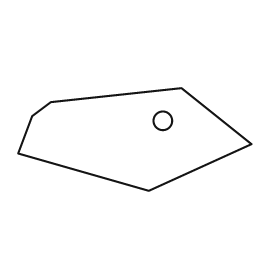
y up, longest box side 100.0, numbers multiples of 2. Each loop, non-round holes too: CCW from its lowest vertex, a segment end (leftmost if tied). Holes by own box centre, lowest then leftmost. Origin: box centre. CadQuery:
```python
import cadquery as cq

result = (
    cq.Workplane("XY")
    .moveTo(6.0, -22.0)
    .lineTo(50.0, -2.0)
    .lineTo(20.0, 22.0)
    .lineTo(-36.0, 16.0)
    .lineTo(-44.0, 10.0)
    .lineTo(-50.0, -6.0)
    .close()
    .moveTo(12.0, 8.0)
    .circle(4.0)
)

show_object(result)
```